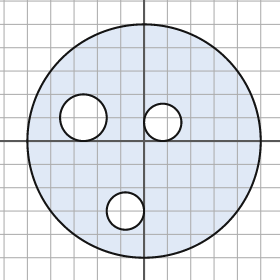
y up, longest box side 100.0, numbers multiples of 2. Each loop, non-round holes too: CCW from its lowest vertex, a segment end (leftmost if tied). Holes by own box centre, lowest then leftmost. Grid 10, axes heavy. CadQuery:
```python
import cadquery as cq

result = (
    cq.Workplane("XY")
    .moveTo(0.0, 0.0)
    .circle(50.0)
    .moveTo(-8.0, -30.0)
    .circle(8.0)
    .moveTo(8.0, 8.0)
    .circle(8.0)
    .moveTo(-26.0, 10.0)
    .circle(10.0)
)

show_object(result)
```